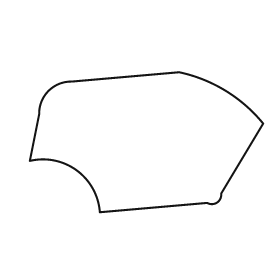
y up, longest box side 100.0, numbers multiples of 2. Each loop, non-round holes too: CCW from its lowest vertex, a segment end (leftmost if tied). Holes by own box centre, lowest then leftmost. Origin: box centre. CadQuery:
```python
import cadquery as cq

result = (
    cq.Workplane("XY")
    .moveTo(-20.0, -30.0)
    .lineTo(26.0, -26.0)
    .threePointArc((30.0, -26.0), (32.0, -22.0))
    .lineTo(50.0, 8.0)
    .threePointArc((34.0, 22.0), (14.0, 30.0))
    .lineTo(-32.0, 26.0)
    .threePointArc((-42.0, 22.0), (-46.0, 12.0))
    .lineTo(-50.0, -8.0)
    .threePointArc((-30.0, -12.0), (-20.0, -30.0))
    .close()
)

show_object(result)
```